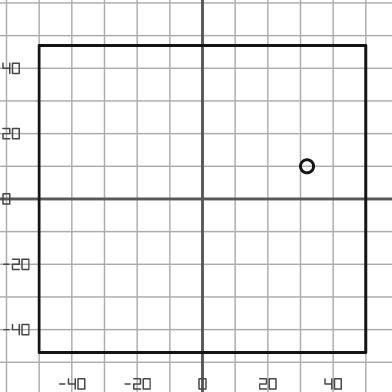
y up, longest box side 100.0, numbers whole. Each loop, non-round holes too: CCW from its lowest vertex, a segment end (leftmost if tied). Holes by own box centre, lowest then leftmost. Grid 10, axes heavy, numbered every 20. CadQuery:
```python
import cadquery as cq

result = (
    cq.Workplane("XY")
    .moveTo(-50.0, -47.0)
    .lineTo(50.0, -47.0)
    .lineTo(50.0, 47.0)
    .lineTo(-50.0, 47.0)
    .close()
    .moveTo(32.0, 10.0)
    .circle(2.0)
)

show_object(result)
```